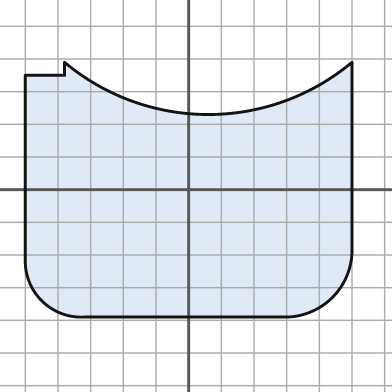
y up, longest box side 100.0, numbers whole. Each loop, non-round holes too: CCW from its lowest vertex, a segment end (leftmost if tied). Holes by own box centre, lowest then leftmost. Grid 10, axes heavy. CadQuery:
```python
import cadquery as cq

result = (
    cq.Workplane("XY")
    .moveTo(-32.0, -39.0)
    .lineTo(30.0, -39.0)
    .threePointArc((44.0, -33.0), (50.0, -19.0))
    .lineTo(50.0, 39.0)
    .threePointArc((6.0, 23.0), (-38.0, 39.0))
    .lineTo(-38.0, 35.0)
    .lineTo(-50.0, 35.0)
    .lineTo(-50.0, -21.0)
    .threePointArc((-45.0, -34.0), (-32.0, -39.0))
    .close()
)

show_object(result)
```